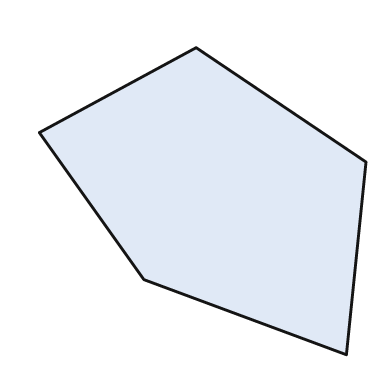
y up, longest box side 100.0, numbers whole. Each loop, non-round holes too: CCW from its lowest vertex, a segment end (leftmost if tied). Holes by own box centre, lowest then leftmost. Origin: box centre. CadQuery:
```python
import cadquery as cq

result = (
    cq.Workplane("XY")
    .moveTo(44.0, -47.0)
    .lineTo(50.0, 12.0)
    .lineTo(-2.0, 47.0)
    .lineTo(-50.0, 21.0)
    .lineTo(-18.0, -24.0)
    .close()
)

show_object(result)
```